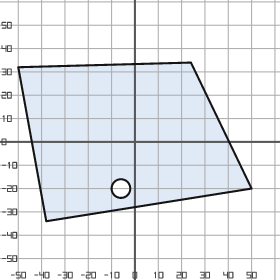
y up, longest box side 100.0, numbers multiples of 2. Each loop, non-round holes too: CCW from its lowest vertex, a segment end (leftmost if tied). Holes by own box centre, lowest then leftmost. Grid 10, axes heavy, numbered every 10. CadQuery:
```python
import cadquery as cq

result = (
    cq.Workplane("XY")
    .moveTo(-38.0, -34.0)
    .lineTo(50.0, -20.0)
    .lineTo(24.0, 34.0)
    .lineTo(-50.0, 32.0)
    .close()
    .moveTo(-6.0, -20.0)
    .circle(4.0)
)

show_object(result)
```